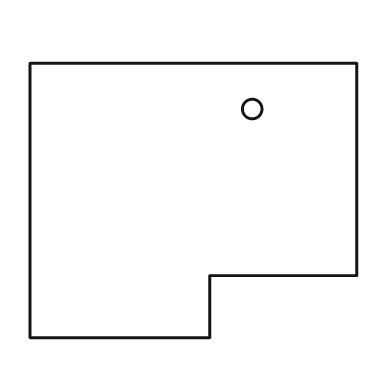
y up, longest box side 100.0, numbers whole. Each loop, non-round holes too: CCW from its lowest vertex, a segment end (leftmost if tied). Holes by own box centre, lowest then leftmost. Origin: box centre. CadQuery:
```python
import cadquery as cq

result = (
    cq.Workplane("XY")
    .moveTo(-50.0, -42.0)
    .lineTo(5.0, -42.0)
    .lineTo(5.0, -23.0)
    .lineTo(50.0, -23.0)
    .lineTo(50.0, 42.0)
    .lineTo(-50.0, 42.0)
    .close()
    .moveTo(18.0, 28.0)
    .circle(3.0)
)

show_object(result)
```